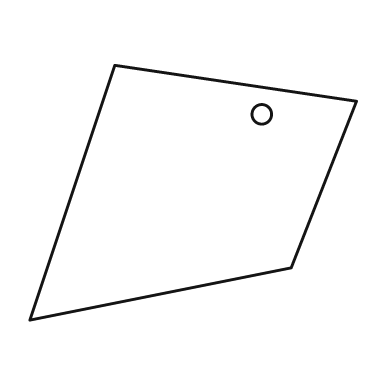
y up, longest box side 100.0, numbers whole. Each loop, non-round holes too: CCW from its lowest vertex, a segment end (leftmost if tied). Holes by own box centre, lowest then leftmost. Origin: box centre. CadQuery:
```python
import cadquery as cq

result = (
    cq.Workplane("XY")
    .moveTo(-50.0, -39.0)
    .lineTo(30.0, -23.0)
    .lineTo(50.0, 28.0)
    .lineTo(-24.0, 39.0)
    .close()
    .moveTo(21.0, 24.0)
    .circle(3.0)
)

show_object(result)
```